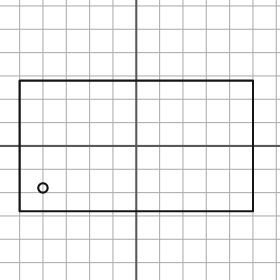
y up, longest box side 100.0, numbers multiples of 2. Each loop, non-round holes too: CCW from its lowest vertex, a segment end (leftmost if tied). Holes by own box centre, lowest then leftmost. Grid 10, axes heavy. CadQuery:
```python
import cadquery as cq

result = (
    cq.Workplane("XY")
    .moveTo(-50.0, -28.0)
    .lineTo(50.0, -28.0)
    .lineTo(50.0, 28.0)
    .lineTo(-50.0, 28.0)
    .close()
    .moveTo(-40.0, -18.0)
    .circle(2.0)
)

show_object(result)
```